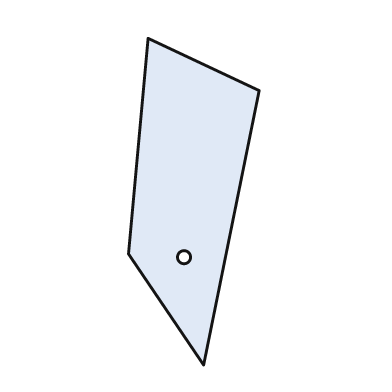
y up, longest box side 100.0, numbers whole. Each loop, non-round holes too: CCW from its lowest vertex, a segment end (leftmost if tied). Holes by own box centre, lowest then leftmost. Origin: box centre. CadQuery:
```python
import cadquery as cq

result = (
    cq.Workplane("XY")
    .moveTo(3.0, -50.0)
    .lineTo(20.0, 34.0)
    .lineTo(-14.0, 50.0)
    .lineTo(-20.0, -16.0)
    .close()
    .moveTo(-3.0, -17.0)
    .circle(2.0)
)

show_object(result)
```